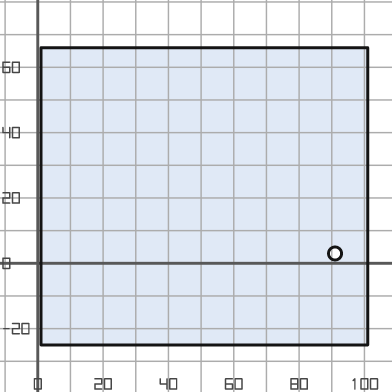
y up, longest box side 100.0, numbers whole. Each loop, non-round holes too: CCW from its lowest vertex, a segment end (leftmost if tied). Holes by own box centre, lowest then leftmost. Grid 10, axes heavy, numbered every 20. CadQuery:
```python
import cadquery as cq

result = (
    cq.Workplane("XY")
    .moveTo(1.0, -25.0)
    .lineTo(101.0, -25.0)
    .lineTo(101.0, 66.0)
    .lineTo(1.0, 66.0)
    .close()
    .moveTo(91.0, 3.0)
    .circle(2.0)
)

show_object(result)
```